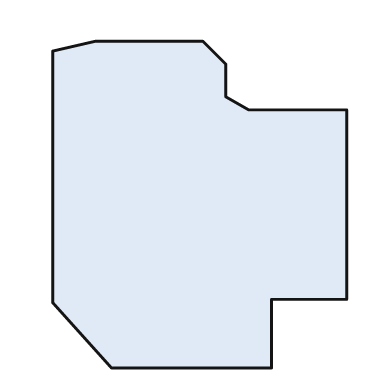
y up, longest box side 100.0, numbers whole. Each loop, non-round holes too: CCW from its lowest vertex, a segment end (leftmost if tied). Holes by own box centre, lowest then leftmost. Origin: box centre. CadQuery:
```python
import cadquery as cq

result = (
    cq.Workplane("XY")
    .moveTo(-27.0, -50.0)
    .lineTo(22.0, -50.0)
    .lineTo(22.0, -29.0)
    .lineTo(45.0, -29.0)
    .lineTo(45.0, 29.0)
    .lineTo(15.0, 29.0)
    .lineTo(8.0, 33.0)
    .lineTo(8.0, 43.0)
    .lineTo(1.0, 50.0)
    .lineTo(-32.0, 50.0)
    .lineTo(-45.0, 47.0)
    .lineTo(-45.0, -30.0)
    .close()
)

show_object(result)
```